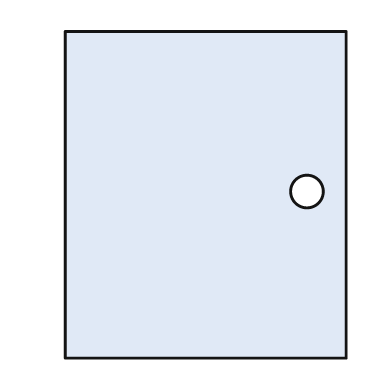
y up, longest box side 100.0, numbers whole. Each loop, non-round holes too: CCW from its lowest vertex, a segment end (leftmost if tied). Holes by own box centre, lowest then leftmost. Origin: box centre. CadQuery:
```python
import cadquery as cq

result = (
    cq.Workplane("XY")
    .moveTo(-43.0, -50.0)
    .lineTo(43.0, -50.0)
    .lineTo(43.0, 50.0)
    .lineTo(-43.0, 50.0)
    .close()
    .moveTo(31.0, 1.0)
    .circle(5.0)
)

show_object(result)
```